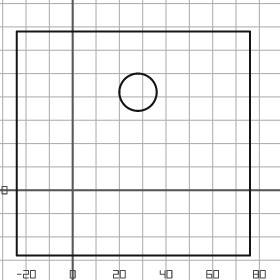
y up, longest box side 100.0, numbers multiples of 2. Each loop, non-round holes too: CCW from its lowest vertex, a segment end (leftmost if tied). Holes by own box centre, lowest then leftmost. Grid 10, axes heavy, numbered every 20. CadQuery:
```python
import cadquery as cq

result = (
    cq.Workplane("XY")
    .moveTo(-24.0, -28.0)
    .lineTo(76.0, -28.0)
    .lineTo(76.0, 68.0)
    .lineTo(-24.0, 68.0)
    .close()
    .moveTo(28.0, 42.0)
    .circle(8.0)
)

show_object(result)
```